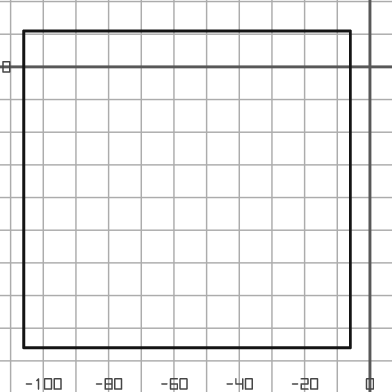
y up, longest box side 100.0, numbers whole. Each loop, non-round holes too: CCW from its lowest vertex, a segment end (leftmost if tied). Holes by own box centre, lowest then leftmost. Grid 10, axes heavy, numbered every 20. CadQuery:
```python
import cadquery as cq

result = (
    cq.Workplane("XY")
    .moveTo(-106.0, -86.0)
    .lineTo(-6.0, -86.0)
    .lineTo(-6.0, 11.0)
    .lineTo(-106.0, 11.0)
    .close()
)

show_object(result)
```